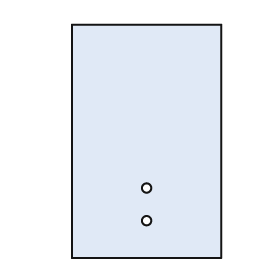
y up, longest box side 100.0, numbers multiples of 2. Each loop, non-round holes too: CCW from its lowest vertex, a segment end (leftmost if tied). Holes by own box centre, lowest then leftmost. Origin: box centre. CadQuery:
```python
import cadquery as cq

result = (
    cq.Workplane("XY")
    .moveTo(-32.0, -50.0)
    .lineTo(32.0, -50.0)
    .lineTo(32.0, 50.0)
    .lineTo(-32.0, 50.0)
    .close()
    .moveTo(0.0, -34.0)
    .circle(2.0)
    .moveTo(0.0, -20.0)
    .circle(2.0)
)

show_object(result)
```